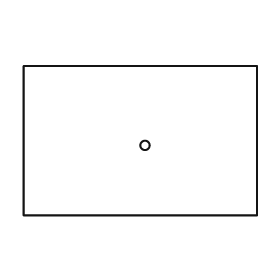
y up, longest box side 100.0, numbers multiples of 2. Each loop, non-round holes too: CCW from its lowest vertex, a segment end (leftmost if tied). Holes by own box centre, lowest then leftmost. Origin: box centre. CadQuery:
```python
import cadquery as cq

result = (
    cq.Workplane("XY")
    .moveTo(-50.0, -32.0)
    .lineTo(50.0, -32.0)
    .lineTo(50.0, 32.0)
    .lineTo(-50.0, 32.0)
    .close()
    .moveTo(2.0, -2.0)
    .circle(2.0)
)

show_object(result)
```